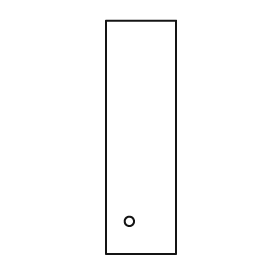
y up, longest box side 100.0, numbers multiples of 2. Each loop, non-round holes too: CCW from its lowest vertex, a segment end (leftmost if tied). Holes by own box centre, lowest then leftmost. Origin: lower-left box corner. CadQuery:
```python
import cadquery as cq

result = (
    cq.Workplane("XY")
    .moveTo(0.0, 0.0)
    .lineTo(30.0, 0.0)
    .lineTo(30.0, 100.0)
    .lineTo(0.0, 100.0)
    .close()
    .moveTo(10.0, 14.0)
    .circle(2.0)
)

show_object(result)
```